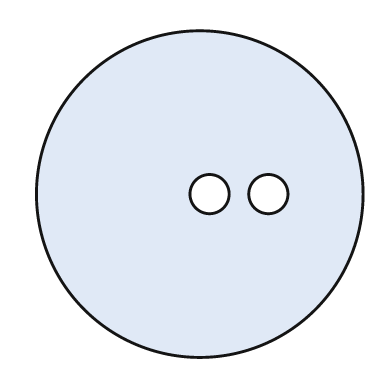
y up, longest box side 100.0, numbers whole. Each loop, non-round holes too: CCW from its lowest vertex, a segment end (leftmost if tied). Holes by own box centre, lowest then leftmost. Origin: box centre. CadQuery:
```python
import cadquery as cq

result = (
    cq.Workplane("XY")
    .moveTo(0.0, 0.0)
    .circle(50.0)
    .moveTo(3.0, 0.0)
    .circle(6.0)
    .moveTo(21.0, 0.0)
    .circle(6.0)
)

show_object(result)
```